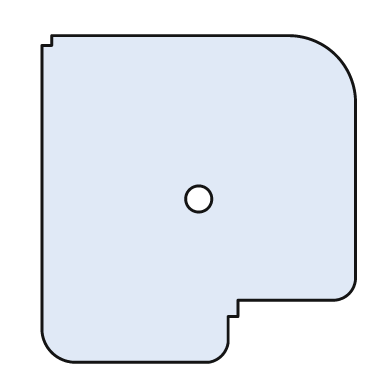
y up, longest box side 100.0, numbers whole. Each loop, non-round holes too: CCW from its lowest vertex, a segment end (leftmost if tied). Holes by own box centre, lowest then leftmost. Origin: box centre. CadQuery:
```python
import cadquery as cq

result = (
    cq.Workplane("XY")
    .moveTo(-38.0, -50.0)
    .lineTo(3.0, -50.0)
    .threePointArc((7.0, -48.0), (9.0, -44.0))
    .lineTo(9.0, -36.0)
    .lineTo(12.0, -36.0)
    .lineTo(12.0, -31.0)
    .lineTo(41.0, -31.0)
    .threePointArc((46.0, -29.0), (48.0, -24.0))
    .lineTo(48.0, 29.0)
    .threePointArc((42.0, 44.0), (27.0, 50.0))
    .lineTo(-45.0, 50.0)
    .lineTo(-45.0, 47.0)
    .lineTo(-48.0, 47.0)
    .lineTo(-48.0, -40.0)
    .threePointArc((-45.0, -47.0), (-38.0, -50.0))
    .close()
    .moveTo(0.0, 0.0)
    .circle(4.0)
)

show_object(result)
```